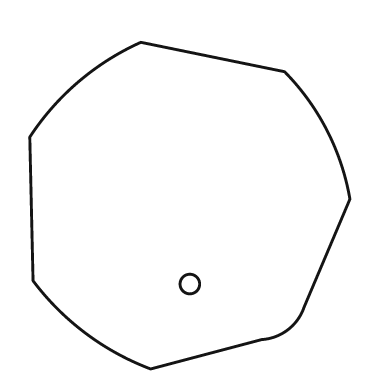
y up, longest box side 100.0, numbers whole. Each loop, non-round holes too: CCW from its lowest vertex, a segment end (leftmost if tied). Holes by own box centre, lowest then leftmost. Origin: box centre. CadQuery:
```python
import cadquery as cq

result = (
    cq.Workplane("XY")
    .moveTo(-12.0, -50.0)
    .lineTo(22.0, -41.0)
    .threePointArc((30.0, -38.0), (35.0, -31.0))
    .lineTo(49.0, 2.0)
    .threePointArc((42.0, 23.0), (29.0, 41.0))
    .lineTo(-15.0, 50.0)
    .threePointArc((-34.0, 38.0), (-49.0, 21.0))
    .lineTo(-48.0, -23.0)
    .threePointArc((-32.0, -39.0), (-12.0, -50.0))
    .close()
    .moveTo(0.0, -24.0)
    .circle(3.0)
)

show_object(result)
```